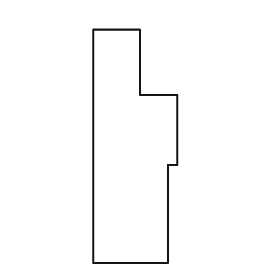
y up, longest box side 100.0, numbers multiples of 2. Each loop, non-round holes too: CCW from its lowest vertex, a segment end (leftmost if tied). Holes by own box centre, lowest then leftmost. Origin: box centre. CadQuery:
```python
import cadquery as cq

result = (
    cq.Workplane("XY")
    .moveTo(-18.0, -50.0)
    .lineTo(14.0, -50.0)
    .lineTo(14.0, -8.0)
    .lineTo(18.0, -8.0)
    .lineTo(18.0, 22.0)
    .lineTo(2.0, 22.0)
    .lineTo(2.0, 50.0)
    .lineTo(-18.0, 50.0)
    .close()
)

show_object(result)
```